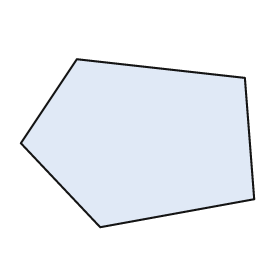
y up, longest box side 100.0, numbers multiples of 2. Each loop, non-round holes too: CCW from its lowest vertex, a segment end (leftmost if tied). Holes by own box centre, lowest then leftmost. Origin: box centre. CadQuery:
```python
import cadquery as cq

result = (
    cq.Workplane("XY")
    .moveTo(-16.0, -36.0)
    .lineTo(50.0, -24.0)
    .lineTo(46.0, 28.0)
    .lineTo(-26.0, 36.0)
    .lineTo(-50.0, 0.0)
    .close()
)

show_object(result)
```